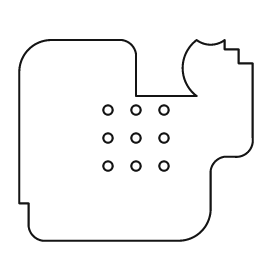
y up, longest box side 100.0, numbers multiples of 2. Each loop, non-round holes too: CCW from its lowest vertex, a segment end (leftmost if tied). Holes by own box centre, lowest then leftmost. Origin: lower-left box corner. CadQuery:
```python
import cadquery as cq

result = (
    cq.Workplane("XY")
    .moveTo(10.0, 0.0)
    .lineTo(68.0, 0.0)
    .threePointArc((78.0, 4.0), (82.0, 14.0))
    .lineTo(82.0, 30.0)
    .threePointArc((84.0, 34.0), (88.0, 36.0))
    .lineTo(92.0, 36.0)
    .threePointArc((98.0, 38.0), (100.0, 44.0))
    .lineTo(100.0, 76.0)
    .lineTo(94.0, 76.0)
    .lineTo(94.0, 82.0)
    .lineTo(88.0, 82.0)
    .lineTo(88.0, 86.0)
    .threePointArc((82.0, 84.0), (76.0, 86.0))
    .threePointArc((70.0, 74.0), (76.0, 62.0))
    .lineTo(50.0, 62.0)
    .lineTo(50.0, 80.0)
    .threePointArc((48.0, 84.0), (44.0, 86.0))
    .lineTo(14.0, 86.0)
    .threePointArc((4.0, 82.0), (0.0, 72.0))
    .lineTo(0.0, 16.0)
    .lineTo(4.0, 16.0)
    .lineTo(4.0, 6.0)
    .threePointArc((6.0, 2.0), (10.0, 0.0))
    .close()
    .moveTo(38.0, 32.0)
    .circle(2.0)
    .moveTo(50.0, 32.0)
    .circle(2.0)
    .moveTo(62.0, 32.0)
    .circle(2.0)
    .moveTo(38.0, 44.0)
    .circle(2.0)
    .moveTo(50.0, 44.0)
    .circle(2.0)
    .moveTo(62.0, 44.0)
    .circle(2.0)
    .moveTo(38.0, 56.0)
    .circle(2.0)
    .moveTo(50.0, 56.0)
    .circle(2.0)
    .moveTo(62.0, 56.0)
    .circle(2.0)
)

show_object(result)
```